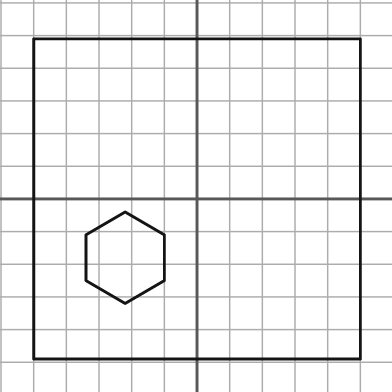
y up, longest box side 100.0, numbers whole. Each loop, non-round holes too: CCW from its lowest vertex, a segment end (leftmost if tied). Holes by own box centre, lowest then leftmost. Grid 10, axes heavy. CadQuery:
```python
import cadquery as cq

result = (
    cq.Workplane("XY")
    .moveTo(-50.0, -49.0)
    .lineTo(50.0, -49.0)
    .lineTo(50.0, 49.0)
    .lineTo(-50.0, 49.0)
    .close()
    .moveTo(-22.0, -32.0)
    .lineTo(-10.0, -25.0)
    .lineTo(-10.0, -11.0)
    .lineTo(-22.0, -4.0)
    .lineTo(-34.0, -11.0)
    .lineTo(-34.0, -25.0)
    .close()
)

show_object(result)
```